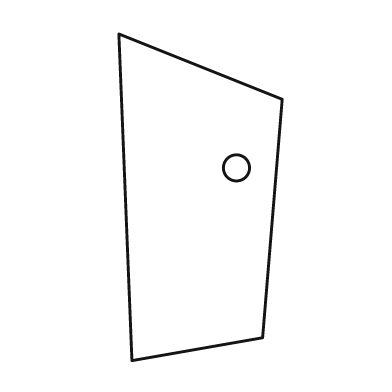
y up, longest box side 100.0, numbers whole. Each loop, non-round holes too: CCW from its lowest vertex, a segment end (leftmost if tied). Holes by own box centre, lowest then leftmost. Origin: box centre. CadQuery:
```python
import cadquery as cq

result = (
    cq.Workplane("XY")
    .moveTo(-21.0, -50.0)
    .lineTo(19.0, -43.0)
    .lineTo(25.0, 30.0)
    .lineTo(-25.0, 50.0)
    .close()
    .moveTo(11.0, 9.0)
    .circle(4.0)
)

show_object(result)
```